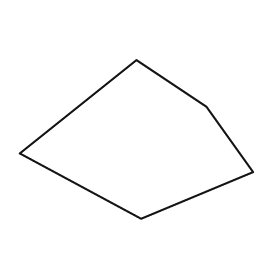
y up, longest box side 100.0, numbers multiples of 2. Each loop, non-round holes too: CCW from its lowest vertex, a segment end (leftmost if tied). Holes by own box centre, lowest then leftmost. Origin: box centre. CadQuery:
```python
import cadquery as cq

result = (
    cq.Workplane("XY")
    .moveTo(2.0, -34.0)
    .lineTo(50.0, -14.0)
    .lineTo(30.0, 14.0)
    .lineTo(0.0, 34.0)
    .lineTo(-50.0, -6.0)
    .close()
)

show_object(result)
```